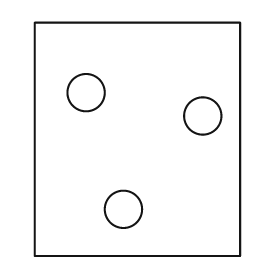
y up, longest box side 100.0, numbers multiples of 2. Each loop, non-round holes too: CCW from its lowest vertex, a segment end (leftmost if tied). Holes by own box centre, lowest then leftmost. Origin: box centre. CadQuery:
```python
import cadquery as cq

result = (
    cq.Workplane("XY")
    .moveTo(-44.0, -50.0)
    .lineTo(44.0, -50.0)
    .lineTo(44.0, 50.0)
    .lineTo(-44.0, 50.0)
    .close()
    .moveTo(-6.0, -30.0)
    .circle(8.0)
    .moveTo(28.0, 10.0)
    .circle(8.0)
    .moveTo(-22.0, 20.0)
    .circle(8.0)
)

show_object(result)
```